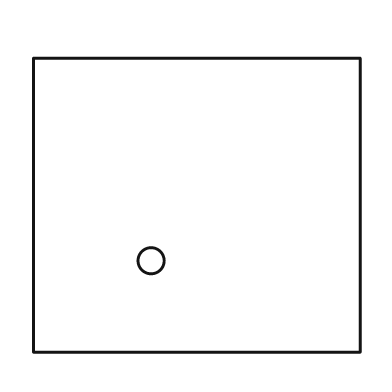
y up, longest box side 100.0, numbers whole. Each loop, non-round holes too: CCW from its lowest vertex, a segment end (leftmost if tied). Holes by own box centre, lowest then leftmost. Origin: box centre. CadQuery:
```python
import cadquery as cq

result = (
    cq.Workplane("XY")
    .moveTo(-50.0, -45.0)
    .lineTo(50.0, -45.0)
    .lineTo(50.0, 45.0)
    .lineTo(-50.0, 45.0)
    .close()
    .moveTo(-14.0, -17.0)
    .circle(4.0)
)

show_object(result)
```